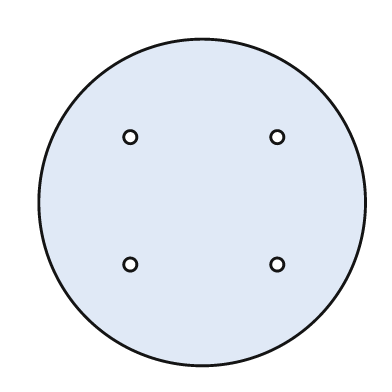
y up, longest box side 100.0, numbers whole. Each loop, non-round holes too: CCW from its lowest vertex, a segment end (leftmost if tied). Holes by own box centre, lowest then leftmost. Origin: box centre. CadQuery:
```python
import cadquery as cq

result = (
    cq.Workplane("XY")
    .moveTo(0.0, 0.0)
    .circle(50.0)
    .moveTo(-22.0, -19.0)
    .circle(2.0)
    .moveTo(23.0, -19.0)
    .circle(2.0)
    .moveTo(-22.0, 20.0)
    .circle(2.0)
    .moveTo(23.0, 20.0)
    .circle(2.0)
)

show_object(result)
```